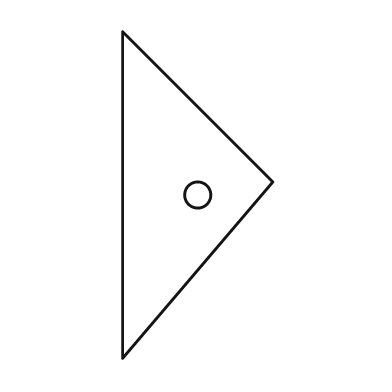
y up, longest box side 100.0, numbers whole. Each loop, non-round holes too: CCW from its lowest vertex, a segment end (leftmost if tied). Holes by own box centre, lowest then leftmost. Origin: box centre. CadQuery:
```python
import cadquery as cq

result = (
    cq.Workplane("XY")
    .moveTo(-23.0, -50.0)
    .lineTo(23.0, 4.0)
    .lineTo(-23.0, 50.0)
    .close()
    .moveTo(0.0, 0.0)
    .circle(4.0)
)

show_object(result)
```